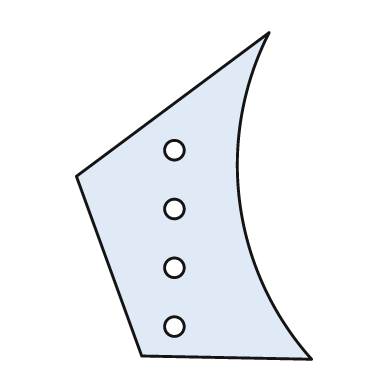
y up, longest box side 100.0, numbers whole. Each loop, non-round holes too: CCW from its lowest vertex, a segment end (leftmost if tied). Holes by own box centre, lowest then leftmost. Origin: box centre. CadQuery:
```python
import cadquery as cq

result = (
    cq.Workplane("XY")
    .moveTo(36.0, -50.0)
    .threePointArc((14.0, -2.0), (23.0, 50.0))
    .lineTo(-36.0, 6.0)
    .lineTo(-16.0, -49.0)
    .close()
    .moveTo(-6.0, -40.0)
    .circle(3.0)
    .moveTo(-6.0, -22.0)
    .circle(3.0)
    .moveTo(-6.0, -4.0)
    .circle(3.0)
    .moveTo(-6.0, 14.0)
    .circle(3.0)
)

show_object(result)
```